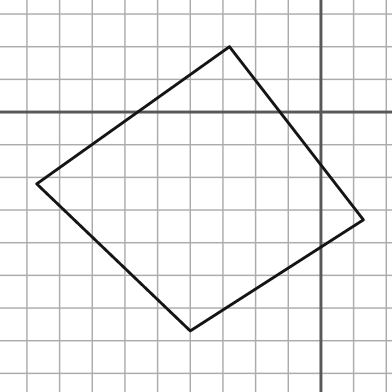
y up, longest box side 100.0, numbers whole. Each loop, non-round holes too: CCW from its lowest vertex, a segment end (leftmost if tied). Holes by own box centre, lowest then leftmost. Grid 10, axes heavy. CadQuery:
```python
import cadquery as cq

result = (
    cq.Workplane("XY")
    .moveTo(-40.0, -67.0)
    .lineTo(13.0, -33.0)
    .lineTo(-28.0, 20.0)
    .lineTo(-87.0, -22.0)
    .close()
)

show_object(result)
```